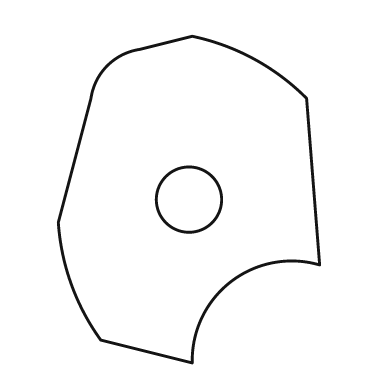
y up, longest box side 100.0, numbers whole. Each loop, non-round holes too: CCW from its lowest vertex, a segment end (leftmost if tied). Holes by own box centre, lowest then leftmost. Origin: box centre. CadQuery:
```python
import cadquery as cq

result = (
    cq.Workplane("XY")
    .moveTo(1.0, -50.0)
    .threePointArc((13.0, -25.0), (40.0, -20.0))
    .lineTo(36.0, 31.0)
    .threePointArc((20.0, 43.0), (1.0, 50.0))
    .lineTo(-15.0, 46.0)
    .threePointArc((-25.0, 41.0), (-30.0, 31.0))
    .lineTo(-40.0, -7.0)
    .threePointArc((-36.0, -26.0), (-27.0, -43.0))
    .close()
    .moveTo(0.0, 0.0)
    .circle(10.0)
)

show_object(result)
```